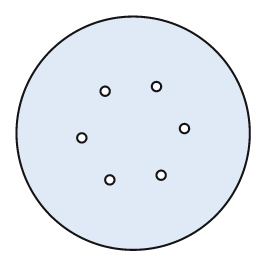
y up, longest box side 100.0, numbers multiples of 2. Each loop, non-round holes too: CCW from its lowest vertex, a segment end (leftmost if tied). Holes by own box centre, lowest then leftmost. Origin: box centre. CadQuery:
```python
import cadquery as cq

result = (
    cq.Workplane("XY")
    .moveTo(0.0, 0.0)
    .circle(50.0)
    .moveTo(-10.0, -20.0)
    .circle(2.0)
    .moveTo(12.0, -18.0)
    .circle(2.0)
    .moveTo(-22.0, -2.0)
    .circle(2.0)
    .moveTo(22.0, 2.0)
    .circle(2.0)
    .moveTo(-12.0, 18.0)
    .circle(2.0)
    .moveTo(10.0, 20.0)
    .circle(2.0)
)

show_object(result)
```